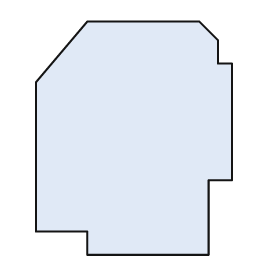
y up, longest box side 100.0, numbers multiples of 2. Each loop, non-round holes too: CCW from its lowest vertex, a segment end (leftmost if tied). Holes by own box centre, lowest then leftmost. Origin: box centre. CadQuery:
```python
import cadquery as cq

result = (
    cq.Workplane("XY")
    .moveTo(-20.0, -50.0)
    .lineTo(32.0, -50.0)
    .lineTo(32.0, -18.0)
    .lineTo(42.0, -18.0)
    .lineTo(42.0, 32.0)
    .lineTo(36.0, 32.0)
    .lineTo(36.0, 42.0)
    .lineTo(28.0, 50.0)
    .lineTo(-20.0, 50.0)
    .lineTo(-42.0, 24.0)
    .lineTo(-42.0, -40.0)
    .lineTo(-20.0, -40.0)
    .close()
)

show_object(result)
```